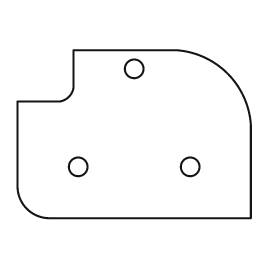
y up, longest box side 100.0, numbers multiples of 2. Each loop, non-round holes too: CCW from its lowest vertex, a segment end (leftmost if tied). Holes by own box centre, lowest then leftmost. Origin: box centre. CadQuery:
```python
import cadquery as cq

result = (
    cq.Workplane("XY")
    .moveTo(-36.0, -36.0)
    .lineTo(50.0, -36.0)
    .lineTo(50.0, 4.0)
    .threePointArc((40.0, 26.0), (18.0, 36.0))
    .lineTo(-26.0, 36.0)
    .lineTo(-26.0, 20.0)
    .threePointArc((-28.0, 16.0), (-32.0, 14.0))
    .lineTo(-50.0, 14.0)
    .lineTo(-50.0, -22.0)
    .threePointArc((-46.0, -32.0), (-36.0, -36.0))
    .close()
    .moveTo(-24.0, -14.0)
    .circle(4.0)
    .moveTo(24.0, -14.0)
    .circle(4.0)
    .moveTo(0.0, 28.0)
    .circle(4.0)
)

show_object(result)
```